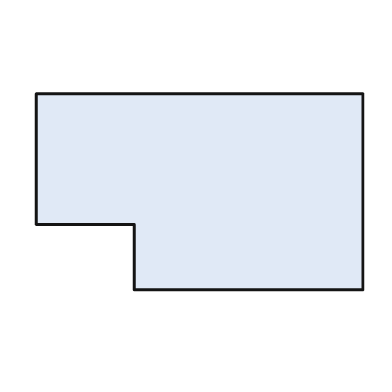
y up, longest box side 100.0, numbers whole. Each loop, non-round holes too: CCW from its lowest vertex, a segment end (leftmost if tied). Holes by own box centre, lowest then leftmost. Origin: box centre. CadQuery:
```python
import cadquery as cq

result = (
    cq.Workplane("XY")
    .moveTo(-20.0, -30.0)
    .lineTo(50.0, -30.0)
    .lineTo(50.0, 30.0)
    .lineTo(-50.0, 30.0)
    .lineTo(-50.0, -10.0)
    .lineTo(-20.0, -10.0)
    .close()
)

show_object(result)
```